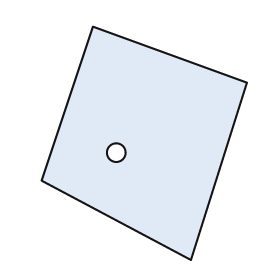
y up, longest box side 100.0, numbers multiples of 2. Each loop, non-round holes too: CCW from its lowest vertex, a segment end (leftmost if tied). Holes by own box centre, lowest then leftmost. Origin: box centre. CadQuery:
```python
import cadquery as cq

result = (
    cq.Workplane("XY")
    .moveTo(20.0, -50.0)
    .lineTo(44.0, 26.0)
    .lineTo(-22.0, 50.0)
    .lineTo(-44.0, -16.0)
    .close()
    .moveTo(-12.0, -4.0)
    .circle(4.0)
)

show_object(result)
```